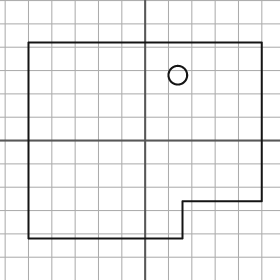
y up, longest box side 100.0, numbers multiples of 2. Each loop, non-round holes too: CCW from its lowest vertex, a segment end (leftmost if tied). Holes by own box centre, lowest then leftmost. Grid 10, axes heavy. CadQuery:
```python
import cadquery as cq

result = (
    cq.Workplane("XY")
    .moveTo(-50.0, -42.0)
    .lineTo(16.0, -42.0)
    .lineTo(16.0, -26.0)
    .lineTo(50.0, -26.0)
    .lineTo(50.0, 42.0)
    .lineTo(-50.0, 42.0)
    .close()
    .moveTo(14.0, 28.0)
    .circle(4.0)
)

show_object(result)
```